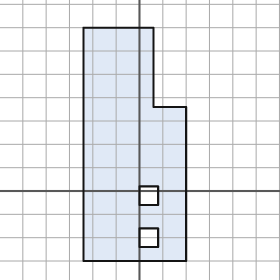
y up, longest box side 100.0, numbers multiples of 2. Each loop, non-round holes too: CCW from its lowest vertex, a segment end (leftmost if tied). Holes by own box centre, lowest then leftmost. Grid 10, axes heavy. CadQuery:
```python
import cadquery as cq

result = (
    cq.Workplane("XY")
    .moveTo(-24.0, -30.0)
    .lineTo(20.0, -30.0)
    .lineTo(20.0, 36.0)
    .lineTo(6.0, 36.0)
    .lineTo(6.0, 70.0)
    .lineTo(-24.0, 70.0)
    .close()
    .moveTo(0.0, -24.0)
    .lineTo(8.0, -24.0)
    .lineTo(8.0, -16.0)
    .lineTo(0.0, -16.0)
    .close()
    .moveTo(0.0, -6.0)
    .lineTo(8.0, -6.0)
    .lineTo(8.0, 2.0)
    .lineTo(0.0, 2.0)
    .close()
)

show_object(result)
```